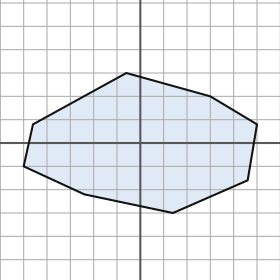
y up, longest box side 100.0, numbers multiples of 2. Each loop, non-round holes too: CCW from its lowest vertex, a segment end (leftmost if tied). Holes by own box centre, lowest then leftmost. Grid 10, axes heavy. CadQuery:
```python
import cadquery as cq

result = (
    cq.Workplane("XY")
    .moveTo(14.0, -30.0)
    .lineTo(46.0, -16.0)
    .lineTo(50.0, 8.0)
    .lineTo(30.0, 20.0)
    .lineTo(-6.0, 30.0)
    .lineTo(-46.0, 8.0)
    .lineTo(-50.0, -10.0)
    .lineTo(-24.0, -22.0)
    .close()
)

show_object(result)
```